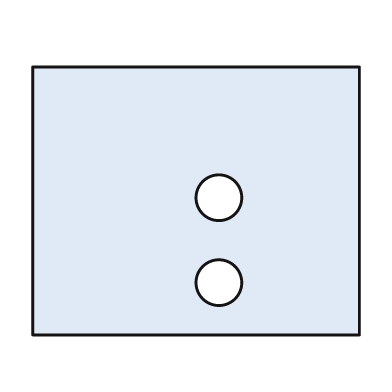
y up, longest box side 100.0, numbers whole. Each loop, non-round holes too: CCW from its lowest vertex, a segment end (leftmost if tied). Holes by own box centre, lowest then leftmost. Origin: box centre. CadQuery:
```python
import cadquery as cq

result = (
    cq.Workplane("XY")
    .moveTo(-50.0, -41.0)
    .lineTo(50.0, -41.0)
    .lineTo(50.0, 41.0)
    .lineTo(-50.0, 41.0)
    .close()
    .moveTo(7.0, -25.0)
    .circle(7.0)
    .moveTo(7.0, 1.0)
    .circle(7.0)
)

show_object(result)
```